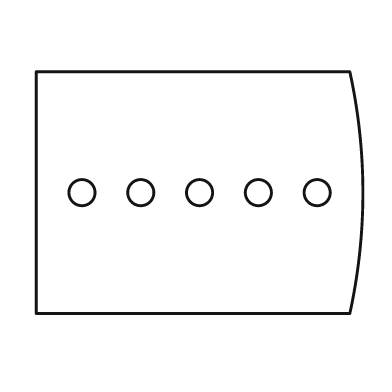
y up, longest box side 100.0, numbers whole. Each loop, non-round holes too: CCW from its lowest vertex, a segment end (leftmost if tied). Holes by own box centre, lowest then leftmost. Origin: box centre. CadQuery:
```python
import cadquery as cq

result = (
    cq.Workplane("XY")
    .moveTo(-50.0, -37.0)
    .lineTo(46.0, -37.0)
    .threePointArc((50.0, 0.0), (46.0, 37.0))
    .lineTo(-50.0, 37.0)
    .close()
    .moveTo(-36.0, 0.0)
    .circle(4.0)
    .moveTo(-18.0, 0.0)
    .circle(4.0)
    .moveTo(0.0, 0.0)
    .circle(4.0)
    .moveTo(18.0, 0.0)
    .circle(4.0)
    .moveTo(36.0, 0.0)
    .circle(4.0)
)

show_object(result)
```